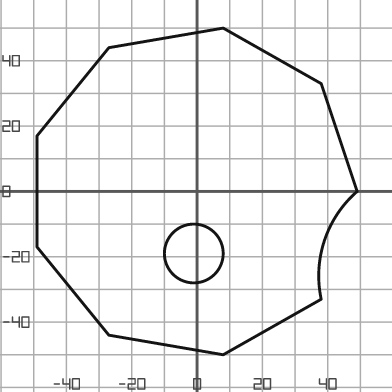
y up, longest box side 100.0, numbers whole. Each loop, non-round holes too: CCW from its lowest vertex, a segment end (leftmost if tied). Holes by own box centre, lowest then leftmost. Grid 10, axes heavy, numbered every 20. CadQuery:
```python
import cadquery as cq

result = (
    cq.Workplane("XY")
    .moveTo(8.0, -50.0)
    .lineTo(38.0, -33.0)
    .threePointArc((39.0, -15.0), (49.0, 0.0))
    .lineTo(38.0, 33.0)
    .lineTo(8.0, 50.0)
    .lineTo(-27.0, 44.0)
    .lineTo(-49.0, 17.0)
    .lineTo(-49.0, -17.0)
    .lineTo(-27.0, -44.0)
    .close()
    .moveTo(-1.0, -19.0)
    .circle(9.0)
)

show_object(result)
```